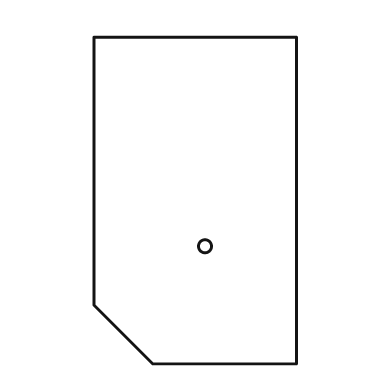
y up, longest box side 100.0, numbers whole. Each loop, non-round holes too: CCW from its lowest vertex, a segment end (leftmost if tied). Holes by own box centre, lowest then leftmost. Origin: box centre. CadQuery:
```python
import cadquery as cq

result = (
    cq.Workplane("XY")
    .moveTo(-13.0, -50.0)
    .lineTo(31.0, -50.0)
    .lineTo(31.0, 50.0)
    .lineTo(-31.0, 50.0)
    .lineTo(-31.0, -32.0)
    .close()
    .moveTo(3.0, -14.0)
    .circle(2.0)
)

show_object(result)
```